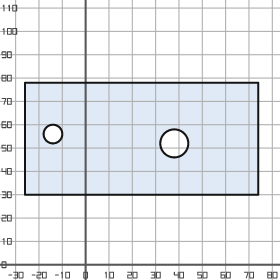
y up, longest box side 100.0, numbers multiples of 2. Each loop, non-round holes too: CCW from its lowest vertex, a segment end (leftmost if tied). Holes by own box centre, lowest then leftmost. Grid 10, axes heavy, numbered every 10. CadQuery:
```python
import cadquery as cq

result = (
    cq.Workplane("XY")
    .moveTo(-26.0, 30.0)
    .lineTo(74.0, 30.0)
    .lineTo(74.0, 78.0)
    .lineTo(-26.0, 78.0)
    .close()
    .moveTo(38.0, 52.0)
    .circle(6.0)
    .moveTo(-14.0, 56.0)
    .circle(4.0)
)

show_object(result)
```